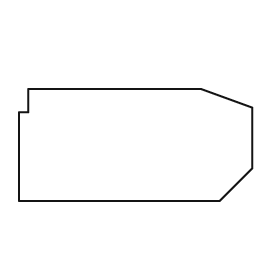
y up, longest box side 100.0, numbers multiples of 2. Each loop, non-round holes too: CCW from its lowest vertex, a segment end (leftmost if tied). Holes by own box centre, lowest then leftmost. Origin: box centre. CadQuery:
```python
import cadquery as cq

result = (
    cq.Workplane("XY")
    .moveTo(-50.0, -24.0)
    .lineTo(36.0, -24.0)
    .lineTo(50.0, -10.0)
    .lineTo(50.0, 16.0)
    .lineTo(28.0, 24.0)
    .lineTo(-46.0, 24.0)
    .lineTo(-46.0, 14.0)
    .lineTo(-50.0, 14.0)
    .close()
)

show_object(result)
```